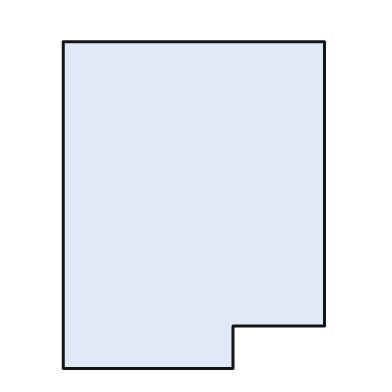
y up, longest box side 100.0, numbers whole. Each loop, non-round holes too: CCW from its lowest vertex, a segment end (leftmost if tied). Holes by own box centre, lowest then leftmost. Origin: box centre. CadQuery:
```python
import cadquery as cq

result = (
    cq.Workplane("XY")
    .moveTo(-40.0, -50.0)
    .lineTo(12.0, -50.0)
    .lineTo(12.0, -37.0)
    .lineTo(40.0, -37.0)
    .lineTo(40.0, 50.0)
    .lineTo(-40.0, 50.0)
    .close()
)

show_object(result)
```